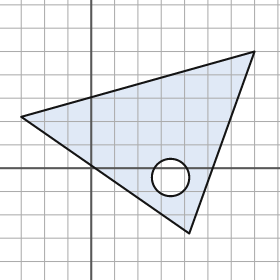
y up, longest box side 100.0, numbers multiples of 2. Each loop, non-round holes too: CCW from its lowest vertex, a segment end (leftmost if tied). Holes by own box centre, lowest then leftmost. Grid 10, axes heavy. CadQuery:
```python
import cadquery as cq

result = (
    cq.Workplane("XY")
    .moveTo(42.0, -28.0)
    .lineTo(70.0, 50.0)
    .lineTo(-30.0, 22.0)
    .close()
    .moveTo(34.0, -4.0)
    .circle(8.0)
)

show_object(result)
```